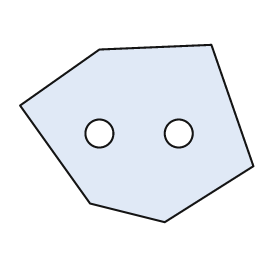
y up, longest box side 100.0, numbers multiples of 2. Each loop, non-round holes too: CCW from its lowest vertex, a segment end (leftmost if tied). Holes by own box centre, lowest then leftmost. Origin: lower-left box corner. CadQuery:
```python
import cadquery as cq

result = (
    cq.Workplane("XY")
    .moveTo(62.0, 0.0)
    .lineTo(100.0, 24.0)
    .lineTo(82.0, 76.0)
    .lineTo(34.0, 74.0)
    .lineTo(0.0, 50.0)
    .lineTo(30.0, 8.0)
    .close()
    .moveTo(34.0, 38.0)
    .circle(6.0)
    .moveTo(68.0, 38.0)
    .circle(6.0)
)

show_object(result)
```